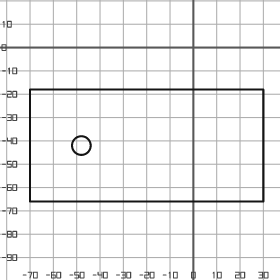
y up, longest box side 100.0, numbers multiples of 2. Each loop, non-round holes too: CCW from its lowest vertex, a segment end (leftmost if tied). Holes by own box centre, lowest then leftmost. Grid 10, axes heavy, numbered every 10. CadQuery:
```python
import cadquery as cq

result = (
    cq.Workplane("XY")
    .moveTo(-70.0, -66.0)
    .lineTo(30.0, -66.0)
    .lineTo(30.0, -18.0)
    .lineTo(-70.0, -18.0)
    .close()
    .moveTo(-48.0, -42.0)
    .circle(4.0)
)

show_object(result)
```